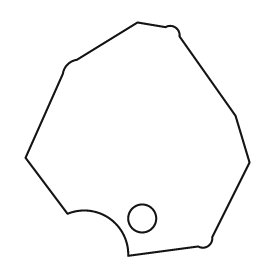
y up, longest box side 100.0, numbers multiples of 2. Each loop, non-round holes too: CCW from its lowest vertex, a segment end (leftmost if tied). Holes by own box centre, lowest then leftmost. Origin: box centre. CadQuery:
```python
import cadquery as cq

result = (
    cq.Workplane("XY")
    .moveTo(-4.0, -50.0)
    .lineTo(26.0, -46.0)
    .threePointArc((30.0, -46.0), (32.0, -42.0))
    .lineTo(48.0, -10.0)
    .lineTo(42.0, 10.0)
    .lineTo(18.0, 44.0)
    .threePointArc((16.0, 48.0), (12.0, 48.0))
    .lineTo(0.0, 50.0)
    .lineTo(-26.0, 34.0)
    .threePointArc((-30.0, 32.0), (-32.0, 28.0))
    .lineTo(-48.0, -8.0)
    .lineTo(-30.0, -32.0)
    .threePointArc((-12.0, -34.0), (-4.0, -50.0))
    .close()
    .moveTo(2.0, -34.0)
    .circle(6.0)
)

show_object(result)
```